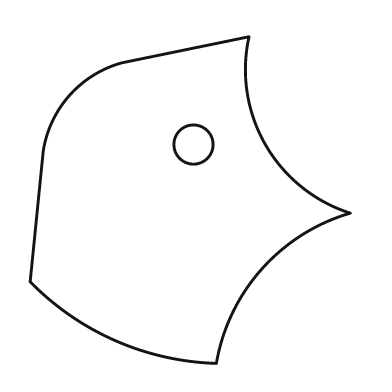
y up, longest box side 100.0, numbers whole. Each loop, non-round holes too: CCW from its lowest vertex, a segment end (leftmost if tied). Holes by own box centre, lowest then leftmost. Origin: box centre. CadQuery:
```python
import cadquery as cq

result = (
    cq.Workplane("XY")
    .moveTo(8.0, -50.0)
    .threePointArc((22.0, -21.0), (49.0, -4.0))
    .threePointArc((23.0, 17.0), (18.0, 50.0))
    .lineTo(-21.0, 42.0)
    .threePointArc((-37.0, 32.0), (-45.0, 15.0))
    .lineTo(-49.0, -25.0)
    .threePointArc((-23.0, -43.0), (8.0, -50.0))
    .close()
    .moveTo(1.0, 17.0)
    .circle(6.0)
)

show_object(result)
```